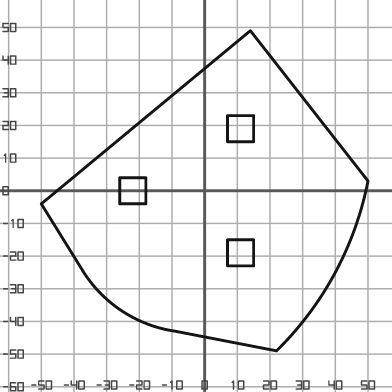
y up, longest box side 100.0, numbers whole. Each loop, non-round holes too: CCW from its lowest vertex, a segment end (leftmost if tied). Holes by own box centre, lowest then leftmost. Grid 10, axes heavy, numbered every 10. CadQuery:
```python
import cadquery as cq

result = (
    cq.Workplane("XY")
    .moveTo(22.0, -49.0)
    .threePointArc((40.0, -25.0), (50.0, 3.0))
    .lineTo(14.0, 49.0)
    .lineTo(-50.0, -4.0)
    .lineTo(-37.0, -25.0)
    .threePointArc((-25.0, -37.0), (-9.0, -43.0))
    .close()
    .moveTo(7.0, -23.0)
    .lineTo(15.0, -23.0)
    .lineTo(15.0, -15.0)
    .lineTo(7.0, -15.0)
    .close()
    .moveTo(-26.0, -4.0)
    .lineTo(-18.0, -4.0)
    .lineTo(-18.0, 4.0)
    .lineTo(-26.0, 4.0)
    .close()
    .moveTo(7.0, 15.0)
    .lineTo(15.0, 15.0)
    .lineTo(15.0, 23.0)
    .lineTo(7.0, 23.0)
    .close()
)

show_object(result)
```